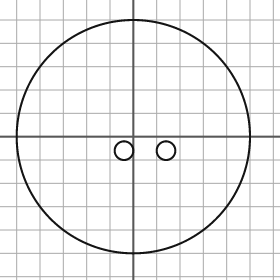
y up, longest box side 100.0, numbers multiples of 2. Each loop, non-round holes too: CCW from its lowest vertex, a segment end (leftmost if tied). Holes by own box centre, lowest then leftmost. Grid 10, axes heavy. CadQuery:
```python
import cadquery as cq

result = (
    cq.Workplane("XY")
    .moveTo(0.0, 0.0)
    .circle(50.0)
    .moveTo(-4.0, -6.0)
    .circle(4.0)
    .moveTo(14.0, -6.0)
    .circle(4.0)
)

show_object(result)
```